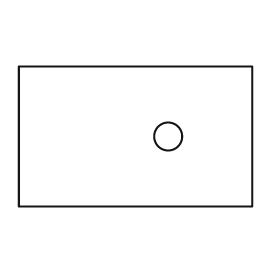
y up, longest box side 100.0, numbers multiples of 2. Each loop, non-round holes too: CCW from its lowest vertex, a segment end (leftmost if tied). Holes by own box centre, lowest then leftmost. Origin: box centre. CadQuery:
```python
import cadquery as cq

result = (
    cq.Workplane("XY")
    .moveTo(-50.0, -30.0)
    .lineTo(50.0, -30.0)
    .lineTo(50.0, 30.0)
    .lineTo(-50.0, 30.0)
    .close()
    .moveTo(14.0, 0.0)
    .circle(6.0)
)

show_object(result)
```